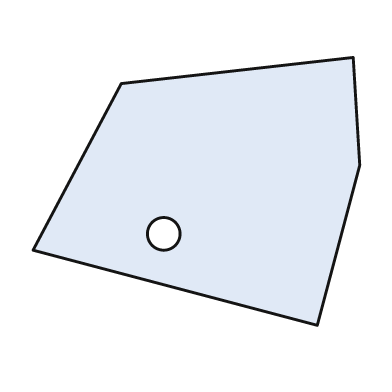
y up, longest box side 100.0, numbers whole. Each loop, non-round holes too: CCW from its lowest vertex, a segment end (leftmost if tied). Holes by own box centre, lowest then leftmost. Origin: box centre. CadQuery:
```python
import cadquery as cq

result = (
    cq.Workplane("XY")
    .moveTo(37.0, -41.0)
    .lineTo(50.0, 8.0)
    .lineTo(48.0, 41.0)
    .lineTo(-23.0, 33.0)
    .lineTo(-50.0, -18.0)
    .close()
    .moveTo(-10.0, -13.0)
    .circle(5.0)
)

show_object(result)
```